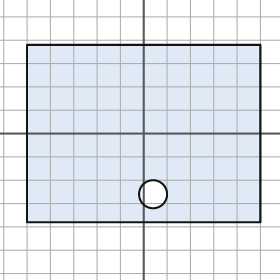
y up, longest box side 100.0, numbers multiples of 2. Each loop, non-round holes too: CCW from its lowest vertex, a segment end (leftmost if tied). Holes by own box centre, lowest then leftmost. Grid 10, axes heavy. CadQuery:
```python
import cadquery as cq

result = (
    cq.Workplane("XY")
    .moveTo(-50.0, -38.0)
    .lineTo(50.0, -38.0)
    .lineTo(50.0, 38.0)
    .lineTo(-50.0, 38.0)
    .close()
    .moveTo(4.0, -26.0)
    .circle(6.0)
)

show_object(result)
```